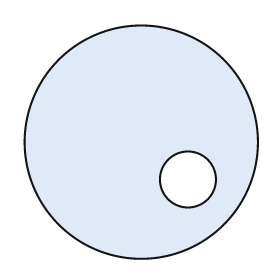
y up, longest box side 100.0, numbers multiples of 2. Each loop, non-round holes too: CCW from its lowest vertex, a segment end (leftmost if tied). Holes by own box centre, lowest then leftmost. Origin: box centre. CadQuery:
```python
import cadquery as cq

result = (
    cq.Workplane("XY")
    .moveTo(0.0, 0.0)
    .circle(50.0)
    .moveTo(20.0, -16.0)
    .circle(12.0)
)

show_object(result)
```